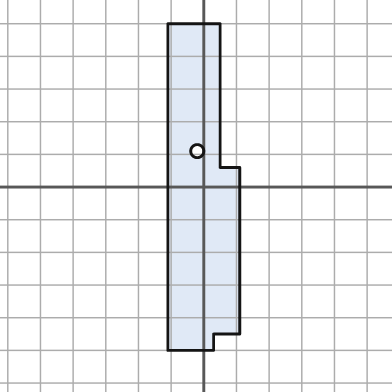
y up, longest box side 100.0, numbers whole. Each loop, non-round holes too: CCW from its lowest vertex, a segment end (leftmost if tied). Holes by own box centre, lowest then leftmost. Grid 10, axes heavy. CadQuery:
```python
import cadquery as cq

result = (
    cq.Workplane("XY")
    .moveTo(-11.0, -50.0)
    .lineTo(3.0, -50.0)
    .lineTo(3.0, -45.0)
    .lineTo(11.0, -45.0)
    .lineTo(11.0, 6.0)
    .lineTo(5.0, 6.0)
    .lineTo(5.0, 50.0)
    .lineTo(-11.0, 50.0)
    .close()
    .moveTo(-2.0, 11.0)
    .circle(2.0)
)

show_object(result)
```